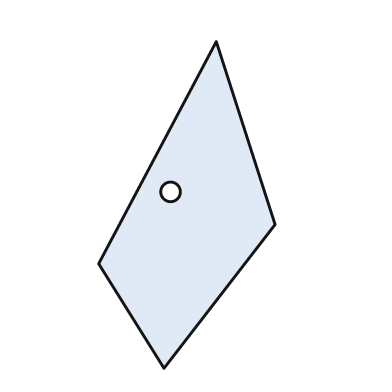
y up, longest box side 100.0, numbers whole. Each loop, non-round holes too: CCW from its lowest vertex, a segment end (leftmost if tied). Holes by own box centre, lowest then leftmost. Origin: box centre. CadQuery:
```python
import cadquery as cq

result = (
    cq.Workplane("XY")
    .moveTo(-7.0, -50.0)
    .lineTo(27.0, -6.0)
    .lineTo(9.0, 50.0)
    .lineTo(-27.0, -18.0)
    .close()
    .moveTo(-5.0, 4.0)
    .circle(3.0)
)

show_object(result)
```